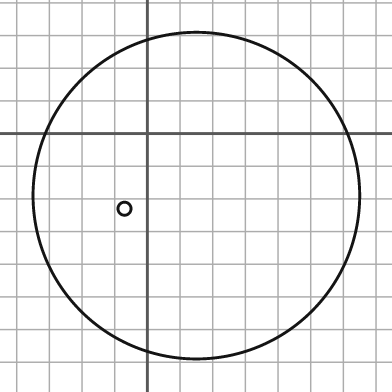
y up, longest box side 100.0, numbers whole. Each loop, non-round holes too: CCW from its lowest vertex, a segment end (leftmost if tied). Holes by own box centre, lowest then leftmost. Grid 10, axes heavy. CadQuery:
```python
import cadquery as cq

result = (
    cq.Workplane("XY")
    .moveTo(15.0, -19.0)
    .circle(50.0)
    .moveTo(-7.0, -23.0)
    .circle(2.0)
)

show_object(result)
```